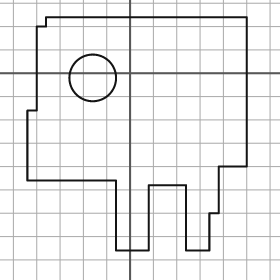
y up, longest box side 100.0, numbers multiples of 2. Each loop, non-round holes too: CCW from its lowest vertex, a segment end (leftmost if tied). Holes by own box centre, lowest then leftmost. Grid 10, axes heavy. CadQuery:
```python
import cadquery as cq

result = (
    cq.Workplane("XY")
    .moveTo(-6.0, -76.0)
    .lineTo(8.0, -76.0)
    .lineTo(8.0, -48.0)
    .lineTo(24.0, -48.0)
    .lineTo(24.0, -76.0)
    .lineTo(34.0, -76.0)
    .lineTo(34.0, -60.0)
    .lineTo(38.0, -60.0)
    .lineTo(38.0, -40.0)
    .lineTo(50.0, -40.0)
    .lineTo(50.0, 24.0)
    .lineTo(-36.0, 24.0)
    .lineTo(-36.0, 20.0)
    .lineTo(-40.0, 20.0)
    .lineTo(-40.0, -16.0)
    .lineTo(-44.0, -16.0)
    .lineTo(-44.0, -46.0)
    .lineTo(-6.0, -46.0)
    .close()
    .moveTo(-16.0, -2.0)
    .circle(10.0)
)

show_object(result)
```